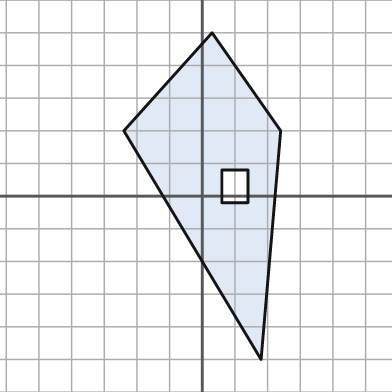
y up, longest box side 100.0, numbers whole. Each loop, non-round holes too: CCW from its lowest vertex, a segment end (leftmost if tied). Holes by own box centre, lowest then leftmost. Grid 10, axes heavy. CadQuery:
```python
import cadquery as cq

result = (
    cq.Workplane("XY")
    .moveTo(18.0, -50.0)
    .lineTo(24.0, 20.0)
    .lineTo(3.0, 50.0)
    .lineTo(-24.0, 20.0)
    .close()
    .moveTo(6.0, -2.0)
    .lineTo(14.0, -2.0)
    .lineTo(14.0, 8.0)
    .lineTo(6.0, 8.0)
    .close()
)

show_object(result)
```